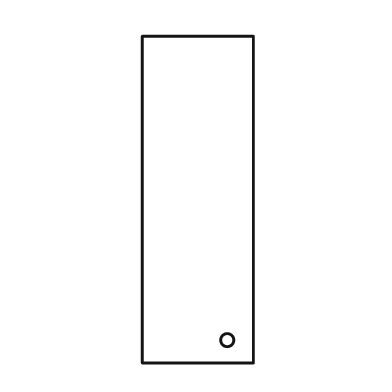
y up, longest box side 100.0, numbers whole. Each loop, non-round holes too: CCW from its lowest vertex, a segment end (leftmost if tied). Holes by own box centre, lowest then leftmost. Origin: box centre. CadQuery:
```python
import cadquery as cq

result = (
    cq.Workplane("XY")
    .moveTo(-17.0, -50.0)
    .lineTo(17.0, -50.0)
    .lineTo(17.0, 50.0)
    .lineTo(-17.0, 50.0)
    .close()
    .moveTo(9.0, -43.0)
    .circle(2.0)
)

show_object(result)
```